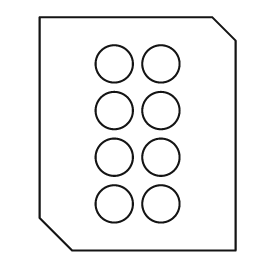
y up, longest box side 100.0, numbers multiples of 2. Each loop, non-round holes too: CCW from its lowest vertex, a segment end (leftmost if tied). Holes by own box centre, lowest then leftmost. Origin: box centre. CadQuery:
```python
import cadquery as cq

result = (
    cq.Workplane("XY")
    .moveTo(-28.0, -50.0)
    .lineTo(42.0, -50.0)
    .lineTo(42.0, 40.0)
    .lineTo(32.0, 50.0)
    .lineTo(-42.0, 50.0)
    .lineTo(-42.0, -36.0)
    .close()
    .moveTo(-10.0, -30.0)
    .circle(8.0)
    .moveTo(10.0, -30.0)
    .circle(8.0)
    .moveTo(-10.0, -10.0)
    .circle(8.0)
    .moveTo(10.0, -10.0)
    .circle(8.0)
    .moveTo(-10.0, 10.0)
    .circle(8.0)
    .moveTo(10.0, 10.0)
    .circle(8.0)
    .moveTo(-10.0, 30.0)
    .circle(8.0)
    .moveTo(10.0, 30.0)
    .circle(8.0)
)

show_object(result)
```